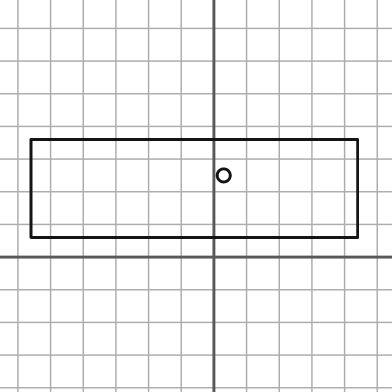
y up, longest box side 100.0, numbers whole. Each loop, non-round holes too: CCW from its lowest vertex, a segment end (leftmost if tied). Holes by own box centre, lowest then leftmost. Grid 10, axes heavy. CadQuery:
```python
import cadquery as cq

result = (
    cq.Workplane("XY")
    .moveTo(-56.0, 6.0)
    .lineTo(44.0, 6.0)
    .lineTo(44.0, 36.0)
    .lineTo(-56.0, 36.0)
    .close()
    .moveTo(3.0, 25.0)
    .circle(2.0)
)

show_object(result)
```